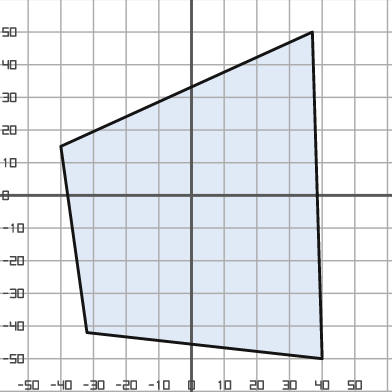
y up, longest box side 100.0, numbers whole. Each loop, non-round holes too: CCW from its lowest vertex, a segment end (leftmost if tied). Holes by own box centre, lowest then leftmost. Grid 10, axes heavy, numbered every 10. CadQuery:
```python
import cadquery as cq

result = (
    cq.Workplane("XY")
    .moveTo(40.0, -50.0)
    .lineTo(37.0, 50.0)
    .lineTo(-40.0, 15.0)
    .lineTo(-32.0, -42.0)
    .close()
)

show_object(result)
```